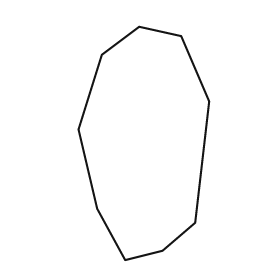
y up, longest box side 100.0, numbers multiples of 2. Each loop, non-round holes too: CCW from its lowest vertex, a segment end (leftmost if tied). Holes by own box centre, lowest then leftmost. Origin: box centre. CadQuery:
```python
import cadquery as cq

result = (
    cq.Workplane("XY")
    .moveTo(-8.0, -50.0)
    .lineTo(8.0, -46.0)
    .lineTo(22.0, -34.0)
    .lineTo(28.0, 18.0)
    .lineTo(16.0, 46.0)
    .lineTo(-2.0, 50.0)
    .lineTo(-18.0, 38.0)
    .lineTo(-28.0, 6.0)
    .lineTo(-20.0, -28.0)
    .close()
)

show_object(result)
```